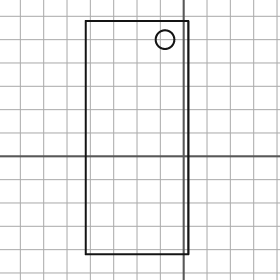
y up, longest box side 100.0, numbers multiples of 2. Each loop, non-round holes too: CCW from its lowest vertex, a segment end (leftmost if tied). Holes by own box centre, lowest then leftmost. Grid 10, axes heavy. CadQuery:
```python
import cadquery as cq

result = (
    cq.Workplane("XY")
    .moveTo(-42.0, -42.0)
    .lineTo(2.0, -42.0)
    .lineTo(2.0, 58.0)
    .lineTo(-42.0, 58.0)
    .close()
    .moveTo(-8.0, 50.0)
    .circle(4.0)
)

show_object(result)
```